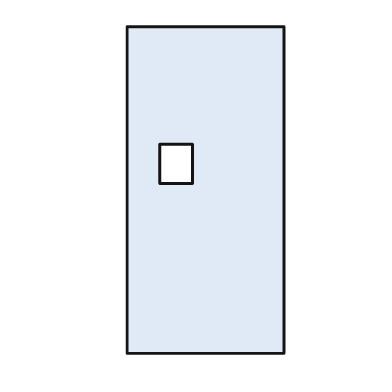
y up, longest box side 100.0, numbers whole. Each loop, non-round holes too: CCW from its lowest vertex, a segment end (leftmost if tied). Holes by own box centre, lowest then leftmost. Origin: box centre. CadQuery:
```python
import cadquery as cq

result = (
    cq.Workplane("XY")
    .moveTo(-24.0, -50.0)
    .lineTo(24.0, -50.0)
    .lineTo(24.0, 50.0)
    .lineTo(-24.0, 50.0)
    .close()
    .moveTo(-14.0, 2.0)
    .lineTo(-4.0, 2.0)
    .lineTo(-4.0, 14.0)
    .lineTo(-14.0, 14.0)
    .close()
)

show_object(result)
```